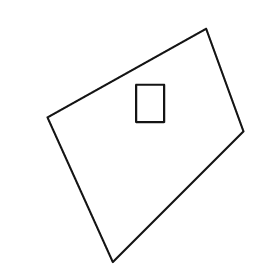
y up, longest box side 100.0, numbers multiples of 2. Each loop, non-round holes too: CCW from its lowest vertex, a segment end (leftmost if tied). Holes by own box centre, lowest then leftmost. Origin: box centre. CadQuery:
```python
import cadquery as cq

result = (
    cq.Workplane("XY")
    .moveTo(-14.0, -50.0)
    .lineTo(42.0, 6.0)
    .lineTo(26.0, 50.0)
    .lineTo(-42.0, 12.0)
    .close()
    .moveTo(-4.0, 10.0)
    .lineTo(8.0, 10.0)
    .lineTo(8.0, 26.0)
    .lineTo(-4.0, 26.0)
    .close()
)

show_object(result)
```